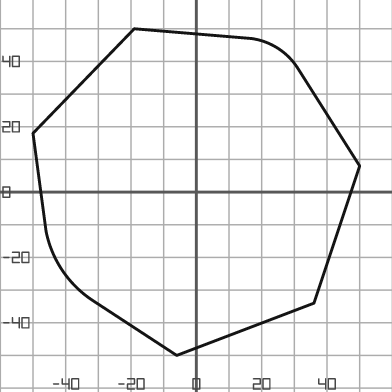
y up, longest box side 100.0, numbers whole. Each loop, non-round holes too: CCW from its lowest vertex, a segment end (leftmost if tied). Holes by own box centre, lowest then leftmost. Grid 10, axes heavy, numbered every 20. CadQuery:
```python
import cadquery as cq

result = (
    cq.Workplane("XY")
    .moveTo(-6.0, -50.0)
    .lineTo(36.0, -34.0)
    .lineTo(50.0, 8.0)
    .lineTo(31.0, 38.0)
    .threePointArc((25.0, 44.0), (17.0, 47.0))
    .lineTo(-19.0, 50.0)
    .lineTo(-50.0, 18.0)
    .lineTo(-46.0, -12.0)
    .threePointArc((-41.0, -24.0), (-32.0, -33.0))
    .close()
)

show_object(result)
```